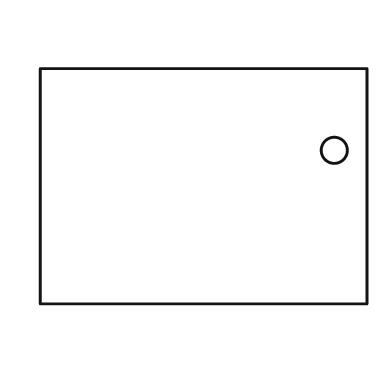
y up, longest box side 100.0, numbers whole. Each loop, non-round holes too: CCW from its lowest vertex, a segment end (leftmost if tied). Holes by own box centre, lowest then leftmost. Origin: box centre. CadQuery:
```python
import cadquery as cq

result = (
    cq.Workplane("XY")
    .moveTo(-50.0, -36.0)
    .lineTo(50.0, -36.0)
    .lineTo(50.0, 36.0)
    .lineTo(-50.0, 36.0)
    .close()
    .moveTo(40.0, 11.0)
    .circle(4.0)
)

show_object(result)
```